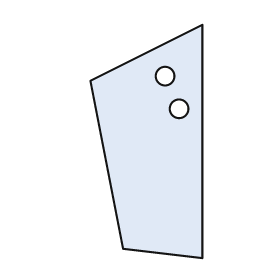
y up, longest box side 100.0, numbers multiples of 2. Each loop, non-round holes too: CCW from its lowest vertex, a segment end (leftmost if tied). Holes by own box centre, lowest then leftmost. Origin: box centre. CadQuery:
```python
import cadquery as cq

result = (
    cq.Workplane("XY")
    .moveTo(24.0, -50.0)
    .lineTo(24.0, 50.0)
    .lineTo(-24.0, 26.0)
    .lineTo(-10.0, -46.0)
    .close()
    .moveTo(14.0, 14.0)
    .circle(4.0)
    .moveTo(8.0, 28.0)
    .circle(4.0)
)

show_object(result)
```